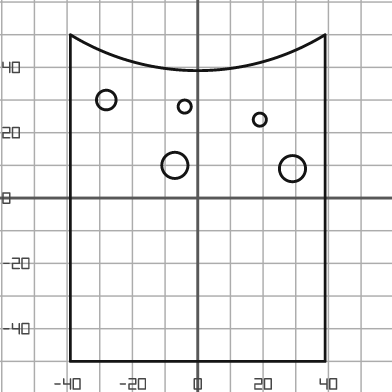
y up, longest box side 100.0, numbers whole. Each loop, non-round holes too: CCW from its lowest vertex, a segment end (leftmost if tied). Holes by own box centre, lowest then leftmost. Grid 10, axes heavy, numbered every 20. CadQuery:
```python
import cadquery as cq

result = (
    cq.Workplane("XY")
    .moveTo(-39.0, -50.0)
    .lineTo(39.0, -50.0)
    .lineTo(39.0, 50.0)
    .threePointArc((0.0, 39.0), (-39.0, 50.0))
    .close()
    .moveTo(29.0, 9.0)
    .circle(4.0)
    .moveTo(-7.0, 10.0)
    .circle(4.0)
    .moveTo(19.0, 24.0)
    .circle(2.0)
    .moveTo(-4.0, 28.0)
    .circle(2.0)
    .moveTo(-28.0, 30.0)
    .circle(3.0)
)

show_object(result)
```